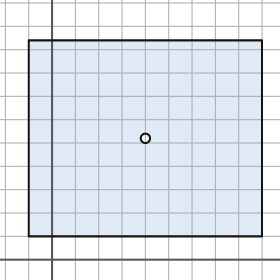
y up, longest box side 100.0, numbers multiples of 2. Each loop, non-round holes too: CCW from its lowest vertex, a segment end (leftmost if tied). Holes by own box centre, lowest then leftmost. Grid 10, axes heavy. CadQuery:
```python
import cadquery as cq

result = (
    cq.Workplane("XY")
    .moveTo(-10.0, 10.0)
    .lineTo(90.0, 10.0)
    .lineTo(90.0, 94.0)
    .lineTo(-10.0, 94.0)
    .close()
    .moveTo(40.0, 52.0)
    .circle(2.0)
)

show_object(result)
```